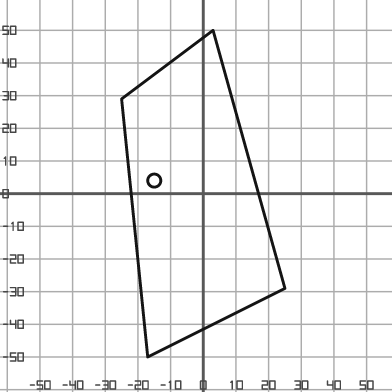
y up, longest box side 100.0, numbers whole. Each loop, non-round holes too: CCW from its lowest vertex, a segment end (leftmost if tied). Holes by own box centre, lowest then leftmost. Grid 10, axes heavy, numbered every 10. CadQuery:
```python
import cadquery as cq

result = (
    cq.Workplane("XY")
    .moveTo(-17.0, -50.0)
    .lineTo(25.0, -29.0)
    .lineTo(3.0, 50.0)
    .lineTo(-25.0, 29.0)
    .close()
    .moveTo(-15.0, 4.0)
    .circle(2.0)
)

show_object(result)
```